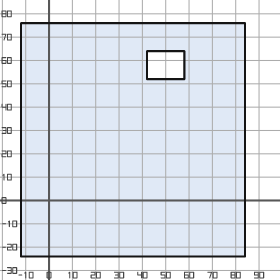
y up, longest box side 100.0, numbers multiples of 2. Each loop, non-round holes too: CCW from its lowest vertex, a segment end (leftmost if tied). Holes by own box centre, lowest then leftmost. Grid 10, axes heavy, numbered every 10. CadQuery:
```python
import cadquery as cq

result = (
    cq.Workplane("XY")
    .moveTo(-12.0, -24.0)
    .lineTo(84.0, -24.0)
    .lineTo(84.0, 76.0)
    .lineTo(-12.0, 76.0)
    .close()
    .moveTo(42.0, 52.0)
    .lineTo(58.0, 52.0)
    .lineTo(58.0, 64.0)
    .lineTo(42.0, 64.0)
    .close()
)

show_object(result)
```